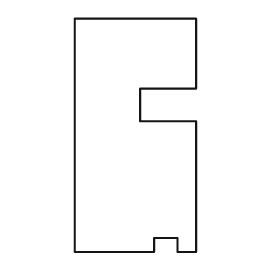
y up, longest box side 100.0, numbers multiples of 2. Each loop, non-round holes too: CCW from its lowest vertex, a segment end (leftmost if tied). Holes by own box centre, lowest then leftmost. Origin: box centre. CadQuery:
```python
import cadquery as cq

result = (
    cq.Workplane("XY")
    .moveTo(-26.0, -50.0)
    .lineTo(8.0, -50.0)
    .lineTo(8.0, -44.0)
    .lineTo(18.0, -44.0)
    .lineTo(18.0, -50.0)
    .lineTo(26.0, -50.0)
    .lineTo(26.0, 6.0)
    .lineTo(2.0, 6.0)
    .lineTo(2.0, 20.0)
    .lineTo(26.0, 20.0)
    .lineTo(26.0, 50.0)
    .lineTo(-26.0, 50.0)
    .close()
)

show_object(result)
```